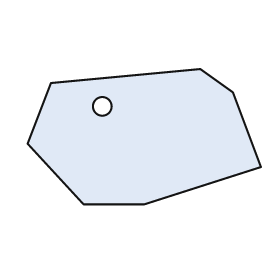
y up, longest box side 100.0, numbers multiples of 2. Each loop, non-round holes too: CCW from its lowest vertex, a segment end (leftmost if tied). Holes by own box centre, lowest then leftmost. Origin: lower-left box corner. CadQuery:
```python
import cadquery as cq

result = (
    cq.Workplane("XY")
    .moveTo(24.0, 0.0)
    .lineTo(50.0, 0.0)
    .lineTo(100.0, 16.0)
    .lineTo(88.0, 48.0)
    .lineTo(74.0, 58.0)
    .lineTo(10.0, 52.0)
    .lineTo(0.0, 26.0)
    .close()
    .moveTo(32.0, 42.0)
    .circle(4.0)
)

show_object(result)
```